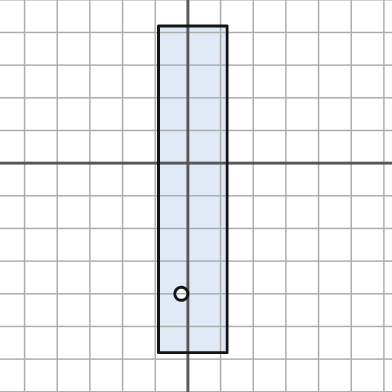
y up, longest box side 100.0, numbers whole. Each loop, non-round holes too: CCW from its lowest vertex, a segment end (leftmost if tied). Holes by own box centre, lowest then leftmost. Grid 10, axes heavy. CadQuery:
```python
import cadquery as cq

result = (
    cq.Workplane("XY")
    .moveTo(-9.0, -58.0)
    .lineTo(12.0, -58.0)
    .lineTo(12.0, 42.0)
    .lineTo(-9.0, 42.0)
    .close()
    .moveTo(-2.0, -40.0)
    .circle(2.0)
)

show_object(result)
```